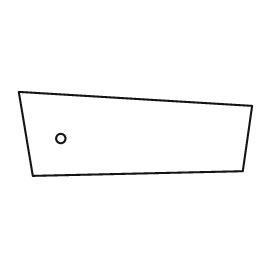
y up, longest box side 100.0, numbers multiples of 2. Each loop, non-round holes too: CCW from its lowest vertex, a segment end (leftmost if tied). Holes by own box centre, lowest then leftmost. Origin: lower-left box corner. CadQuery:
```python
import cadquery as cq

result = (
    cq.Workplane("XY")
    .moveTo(6.0, 0.0)
    .lineTo(96.0, 2.0)
    .lineTo(100.0, 30.0)
    .lineTo(0.0, 36.0)
    .close()
    .moveTo(18.0, 16.0)
    .circle(2.0)
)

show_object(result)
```